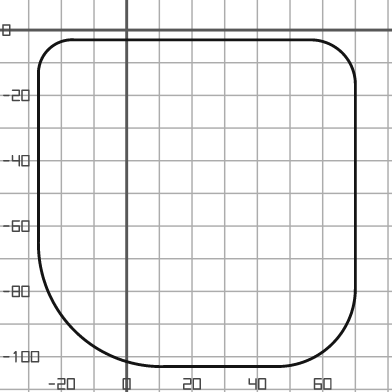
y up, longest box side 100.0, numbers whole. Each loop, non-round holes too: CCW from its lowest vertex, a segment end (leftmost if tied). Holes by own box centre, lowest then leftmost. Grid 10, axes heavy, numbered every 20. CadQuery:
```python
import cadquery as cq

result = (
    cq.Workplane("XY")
    .moveTo(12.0, -103.0)
    .lineTo(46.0, -103.0)
    .threePointArc((63.0, -96.0), (70.0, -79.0))
    .lineTo(70.0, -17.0)
    .threePointArc((66.0, -7.0), (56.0, -3.0))
    .lineTo(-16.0, -3.0)
    .threePointArc((-24.0, -6.0), (-27.0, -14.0))
    .lineTo(-27.0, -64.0)
    .threePointArc((-16.0, -92.0), (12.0, -103.0))
    .close()
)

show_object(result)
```